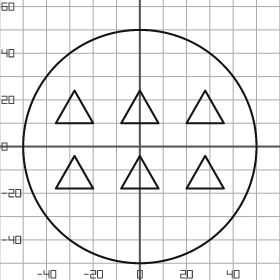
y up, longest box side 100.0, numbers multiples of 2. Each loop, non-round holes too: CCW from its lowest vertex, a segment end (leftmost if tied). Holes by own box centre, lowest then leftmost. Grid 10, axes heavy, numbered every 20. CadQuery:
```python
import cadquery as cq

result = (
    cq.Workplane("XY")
    .moveTo(0.0, 0.0)
    .circle(50.0)
    .moveTo(-36.0, -18.0)
    .lineTo(-20.0, -18.0)
    .lineTo(-28.0, -4.0)
    .close()
    .moveTo(-8.0, -18.0)
    .lineTo(8.0, -18.0)
    .lineTo(0.0, -4.0)
    .close()
    .moveTo(20.0, -18.0)
    .lineTo(36.0, -18.0)
    .lineTo(28.0, -4.0)
    .close()
    .moveTo(-36.0, 10.0)
    .lineTo(-20.0, 10.0)
    .lineTo(-28.0, 24.0)
    .close()
    .moveTo(-8.0, 10.0)
    .lineTo(8.0, 10.0)
    .lineTo(0.0, 24.0)
    .close()
    .moveTo(20.0, 10.0)
    .lineTo(36.0, 10.0)
    .lineTo(28.0, 24.0)
    .close()
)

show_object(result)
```